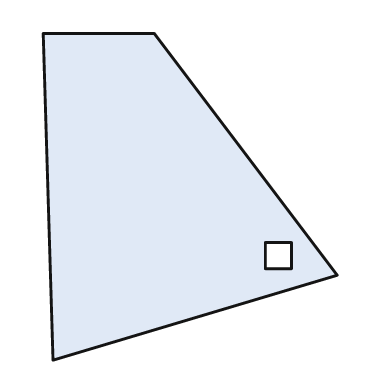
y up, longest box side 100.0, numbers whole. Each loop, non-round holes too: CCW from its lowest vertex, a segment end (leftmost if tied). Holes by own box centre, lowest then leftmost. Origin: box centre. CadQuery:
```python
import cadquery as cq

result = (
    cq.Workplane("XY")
    .moveTo(-42.0, -50.0)
    .lineTo(45.0, -24.0)
    .lineTo(-11.0, 50.0)
    .lineTo(-45.0, 50.0)
    .close()
    .moveTo(23.0, -22.0)
    .lineTo(31.0, -22.0)
    .lineTo(31.0, -14.0)
    .lineTo(23.0, -14.0)
    .close()
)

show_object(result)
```